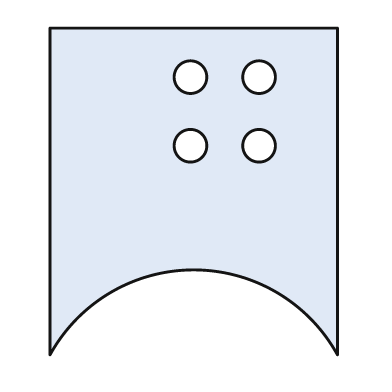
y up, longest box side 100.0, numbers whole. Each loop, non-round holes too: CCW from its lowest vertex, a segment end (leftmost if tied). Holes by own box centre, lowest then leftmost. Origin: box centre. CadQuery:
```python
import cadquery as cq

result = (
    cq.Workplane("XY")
    .moveTo(-44.0, -50.0)
    .threePointArc((0.0, -24.0), (44.0, -50.0))
    .lineTo(44.0, 50.0)
    .lineTo(-44.0, 50.0)
    .close()
    .moveTo(-1.0, 14.0)
    .circle(5.0)
    .moveTo(20.0, 14.0)
    .circle(5.0)
    .moveTo(-1.0, 35.0)
    .circle(5.0)
    .moveTo(20.0, 35.0)
    .circle(5.0)
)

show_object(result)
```